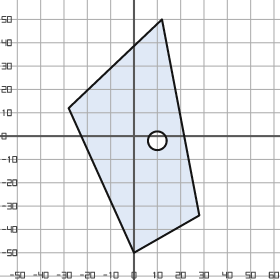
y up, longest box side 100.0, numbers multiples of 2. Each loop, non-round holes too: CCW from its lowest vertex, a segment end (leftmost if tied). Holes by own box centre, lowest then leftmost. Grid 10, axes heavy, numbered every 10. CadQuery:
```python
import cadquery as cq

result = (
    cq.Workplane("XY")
    .moveTo(0.0, -50.0)
    .lineTo(28.0, -34.0)
    .lineTo(12.0, 50.0)
    .lineTo(-28.0, 12.0)
    .close()
    .moveTo(10.0, -2.0)
    .circle(4.0)
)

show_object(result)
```